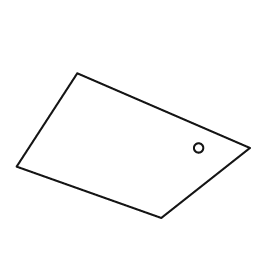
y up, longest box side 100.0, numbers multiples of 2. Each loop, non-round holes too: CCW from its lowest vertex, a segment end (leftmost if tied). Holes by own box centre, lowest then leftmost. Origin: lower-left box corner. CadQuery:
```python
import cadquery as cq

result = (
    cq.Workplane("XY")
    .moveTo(62.0, 0.0)
    .lineTo(100.0, 30.0)
    .lineTo(26.0, 62.0)
    .lineTo(0.0, 22.0)
    .close()
    .moveTo(78.0, 30.0)
    .circle(2.0)
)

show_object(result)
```